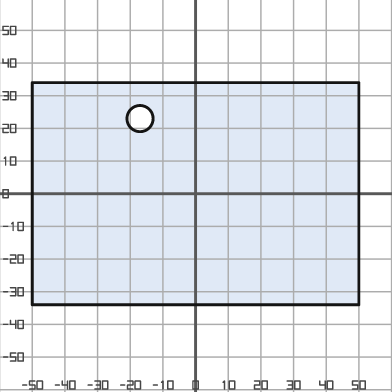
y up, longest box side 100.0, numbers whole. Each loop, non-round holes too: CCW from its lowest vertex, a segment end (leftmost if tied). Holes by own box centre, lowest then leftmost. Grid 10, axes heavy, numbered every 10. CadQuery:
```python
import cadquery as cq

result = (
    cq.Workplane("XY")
    .moveTo(-50.0, -34.0)
    .lineTo(50.0, -34.0)
    .lineTo(50.0, 34.0)
    .lineTo(-50.0, 34.0)
    .close()
    .moveTo(-17.0, 23.0)
    .circle(4.0)
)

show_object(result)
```